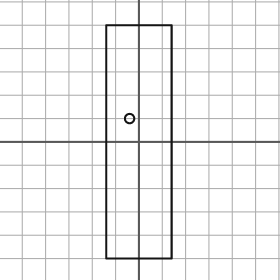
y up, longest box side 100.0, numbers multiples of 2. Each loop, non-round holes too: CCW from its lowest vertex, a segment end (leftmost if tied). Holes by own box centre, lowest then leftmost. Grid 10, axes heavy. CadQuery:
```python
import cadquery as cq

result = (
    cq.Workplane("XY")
    .moveTo(-14.0, -50.0)
    .lineTo(14.0, -50.0)
    .lineTo(14.0, 50.0)
    .lineTo(-14.0, 50.0)
    .close()
    .moveTo(-4.0, 10.0)
    .circle(2.0)
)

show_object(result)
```